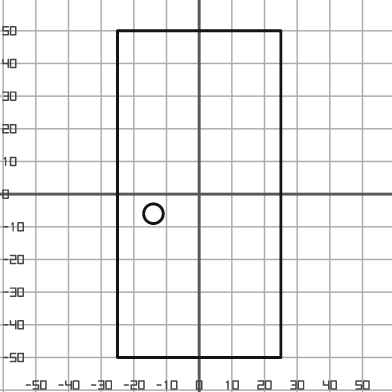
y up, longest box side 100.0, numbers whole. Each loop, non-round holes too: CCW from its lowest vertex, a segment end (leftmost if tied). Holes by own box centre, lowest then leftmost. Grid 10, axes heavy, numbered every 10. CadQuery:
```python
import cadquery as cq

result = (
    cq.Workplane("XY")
    .moveTo(-25.0, -50.0)
    .lineTo(25.0, -50.0)
    .lineTo(25.0, 50.0)
    .lineTo(-25.0, 50.0)
    .close()
    .moveTo(-14.0, -6.0)
    .circle(3.0)
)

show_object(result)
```